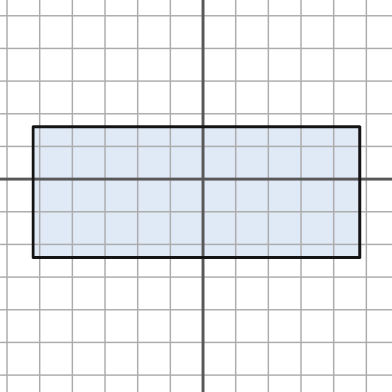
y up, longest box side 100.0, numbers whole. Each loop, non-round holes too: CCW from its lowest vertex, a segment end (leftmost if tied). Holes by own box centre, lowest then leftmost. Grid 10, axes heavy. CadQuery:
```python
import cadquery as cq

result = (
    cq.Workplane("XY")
    .moveTo(-52.0, -24.0)
    .lineTo(48.0, -24.0)
    .lineTo(48.0, 16.0)
    .lineTo(-52.0, 16.0)
    .close()
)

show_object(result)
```